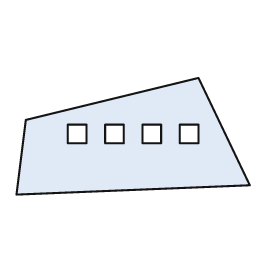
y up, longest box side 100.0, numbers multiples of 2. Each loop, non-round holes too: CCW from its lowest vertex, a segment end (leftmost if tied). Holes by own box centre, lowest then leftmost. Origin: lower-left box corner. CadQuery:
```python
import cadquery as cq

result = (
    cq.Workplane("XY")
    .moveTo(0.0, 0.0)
    .lineTo(100.0, 4.0)
    .lineTo(78.0, 50.0)
    .lineTo(4.0, 32.0)
    .close()
    .moveTo(22.0, 22.0)
    .lineTo(30.0, 22.0)
    .lineTo(30.0, 30.0)
    .lineTo(22.0, 30.0)
    .close()
    .moveTo(38.0, 22.0)
    .lineTo(46.0, 22.0)
    .lineTo(46.0, 30.0)
    .lineTo(38.0, 30.0)
    .close()
    .moveTo(54.0, 22.0)
    .lineTo(62.0, 22.0)
    .lineTo(62.0, 30.0)
    .lineTo(54.0, 30.0)
    .close()
    .moveTo(70.0, 22.0)
    .lineTo(78.0, 22.0)
    .lineTo(78.0, 30.0)
    .lineTo(70.0, 30.0)
    .close()
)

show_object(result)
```